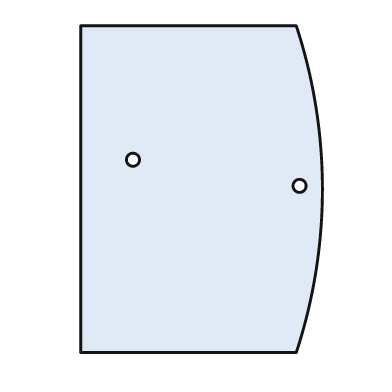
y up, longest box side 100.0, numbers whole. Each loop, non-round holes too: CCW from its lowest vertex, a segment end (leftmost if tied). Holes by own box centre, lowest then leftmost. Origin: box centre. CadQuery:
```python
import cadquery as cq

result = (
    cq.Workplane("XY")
    .moveTo(-37.0, -50.0)
    .lineTo(29.0, -50.0)
    .threePointArc((37.0, 0.0), (29.0, 50.0))
    .lineTo(-37.0, 50.0)
    .close()
    .moveTo(30.0, 1.0)
    .circle(2.0)
    .moveTo(-21.0, 9.0)
    .circle(2.0)
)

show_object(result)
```